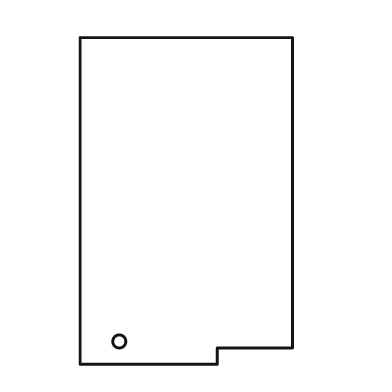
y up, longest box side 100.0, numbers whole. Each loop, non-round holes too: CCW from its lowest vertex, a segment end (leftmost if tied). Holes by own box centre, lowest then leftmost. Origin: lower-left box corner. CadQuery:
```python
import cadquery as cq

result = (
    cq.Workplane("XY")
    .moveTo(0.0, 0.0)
    .lineTo(42.0, 0.0)
    .lineTo(42.0, 5.0)
    .lineTo(65.0, 5.0)
    .lineTo(65.0, 100.0)
    .lineTo(0.0, 100.0)
    .close()
    .moveTo(12.0, 7.0)
    .circle(2.0)
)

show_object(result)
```